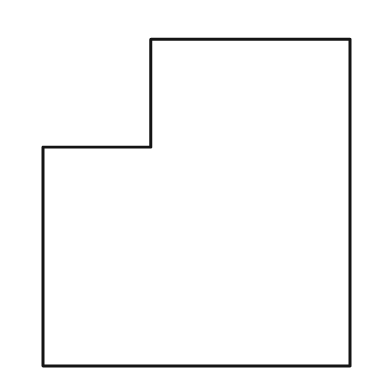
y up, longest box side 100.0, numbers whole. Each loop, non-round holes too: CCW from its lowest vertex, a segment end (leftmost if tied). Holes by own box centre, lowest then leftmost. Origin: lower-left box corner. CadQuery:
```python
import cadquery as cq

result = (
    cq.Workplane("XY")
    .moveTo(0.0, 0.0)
    .lineTo(94.0, 0.0)
    .lineTo(94.0, 100.0)
    .lineTo(33.0, 100.0)
    .lineTo(33.0, 67.0)
    .lineTo(0.0, 67.0)
    .close()
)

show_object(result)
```